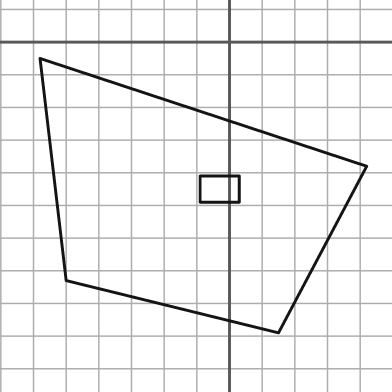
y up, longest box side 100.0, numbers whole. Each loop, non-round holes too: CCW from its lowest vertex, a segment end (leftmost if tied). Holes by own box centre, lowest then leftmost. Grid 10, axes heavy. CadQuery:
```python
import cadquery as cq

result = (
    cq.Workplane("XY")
    .moveTo(15.0, -89.0)
    .lineTo(42.0, -38.0)
    .lineTo(-58.0, -5.0)
    .lineTo(-50.0, -73.0)
    .close()
    .moveTo(-9.0, -49.0)
    .lineTo(3.0, -49.0)
    .lineTo(3.0, -41.0)
    .lineTo(-9.0, -41.0)
    .close()
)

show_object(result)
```